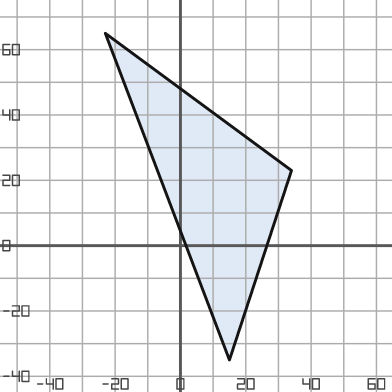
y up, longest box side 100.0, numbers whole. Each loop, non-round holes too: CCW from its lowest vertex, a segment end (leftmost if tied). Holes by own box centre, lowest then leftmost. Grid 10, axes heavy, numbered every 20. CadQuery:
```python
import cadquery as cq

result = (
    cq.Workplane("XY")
    .moveTo(15.0, -35.0)
    .lineTo(34.0, 23.0)
    .lineTo(-23.0, 65.0)
    .close()
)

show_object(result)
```